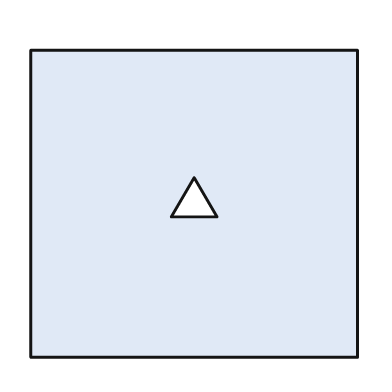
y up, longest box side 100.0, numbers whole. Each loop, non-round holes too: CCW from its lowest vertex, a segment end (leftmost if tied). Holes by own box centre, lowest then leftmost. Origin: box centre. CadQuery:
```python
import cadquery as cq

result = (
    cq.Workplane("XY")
    .moveTo(-50.0, -47.0)
    .lineTo(50.0, -47.0)
    .lineTo(50.0, 47.0)
    .lineTo(-50.0, 47.0)
    .close()
    .moveTo(-7.0, -4.0)
    .lineTo(7.0, -4.0)
    .lineTo(0.0, 8.0)
    .close()
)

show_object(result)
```